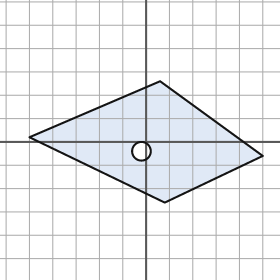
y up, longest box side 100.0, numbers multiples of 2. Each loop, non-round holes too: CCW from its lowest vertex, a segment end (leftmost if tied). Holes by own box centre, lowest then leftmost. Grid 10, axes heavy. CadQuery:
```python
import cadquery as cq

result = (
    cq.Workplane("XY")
    .moveTo(8.0, -26.0)
    .lineTo(50.0, -6.0)
    .lineTo(6.0, 26.0)
    .lineTo(-50.0, 2.0)
    .close()
    .moveTo(-2.0, -4.0)
    .circle(4.0)
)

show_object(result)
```